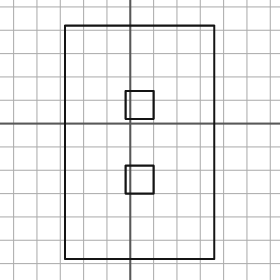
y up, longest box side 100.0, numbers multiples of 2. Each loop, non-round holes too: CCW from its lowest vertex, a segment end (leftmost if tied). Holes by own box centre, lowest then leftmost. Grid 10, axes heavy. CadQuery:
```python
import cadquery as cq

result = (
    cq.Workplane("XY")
    .moveTo(-28.0, -58.0)
    .lineTo(36.0, -58.0)
    .lineTo(36.0, 42.0)
    .lineTo(-28.0, 42.0)
    .close()
    .moveTo(-2.0, -30.0)
    .lineTo(10.0, -30.0)
    .lineTo(10.0, -18.0)
    .lineTo(-2.0, -18.0)
    .close()
    .moveTo(-2.0, 2.0)
    .lineTo(10.0, 2.0)
    .lineTo(10.0, 14.0)
    .lineTo(-2.0, 14.0)
    .close()
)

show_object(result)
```